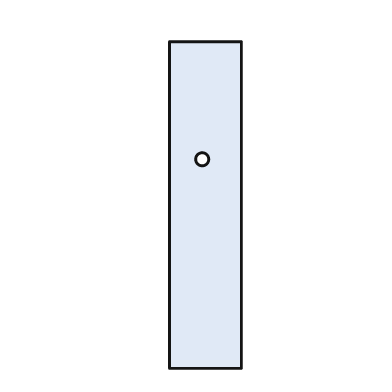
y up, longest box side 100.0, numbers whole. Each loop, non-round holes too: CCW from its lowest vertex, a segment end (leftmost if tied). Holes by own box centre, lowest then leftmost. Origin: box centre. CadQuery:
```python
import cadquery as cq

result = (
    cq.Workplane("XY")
    .moveTo(-11.0, -50.0)
    .lineTo(11.0, -50.0)
    .lineTo(11.0, 50.0)
    .lineTo(-11.0, 50.0)
    .close()
    .moveTo(-1.0, 14.0)
    .circle(2.0)
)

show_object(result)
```